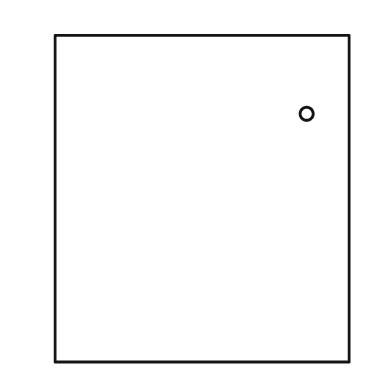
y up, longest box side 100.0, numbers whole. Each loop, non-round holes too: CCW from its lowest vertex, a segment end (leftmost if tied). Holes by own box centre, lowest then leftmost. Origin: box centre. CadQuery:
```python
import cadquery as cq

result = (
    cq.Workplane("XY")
    .moveTo(-45.0, -50.0)
    .lineTo(45.0, -50.0)
    .lineTo(45.0, 50.0)
    .lineTo(-45.0, 50.0)
    .close()
    .moveTo(32.0, 26.0)
    .circle(2.0)
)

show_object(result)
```